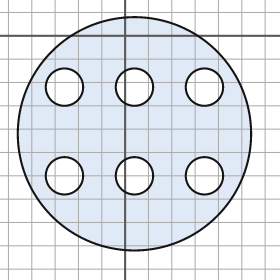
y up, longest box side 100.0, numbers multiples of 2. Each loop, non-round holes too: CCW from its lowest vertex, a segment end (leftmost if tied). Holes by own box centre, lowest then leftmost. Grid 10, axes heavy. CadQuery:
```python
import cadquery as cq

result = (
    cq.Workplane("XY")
    .moveTo(4.0, -42.0)
    .circle(50.0)
    .moveTo(-26.0, -60.0)
    .circle(8.0)
    .moveTo(4.0, -60.0)
    .circle(8.0)
    .moveTo(34.0, -60.0)
    .circle(8.0)
    .moveTo(-26.0, -22.0)
    .circle(8.0)
    .moveTo(4.0, -22.0)
    .circle(8.0)
    .moveTo(34.0, -22.0)
    .circle(8.0)
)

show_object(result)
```